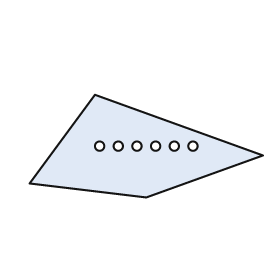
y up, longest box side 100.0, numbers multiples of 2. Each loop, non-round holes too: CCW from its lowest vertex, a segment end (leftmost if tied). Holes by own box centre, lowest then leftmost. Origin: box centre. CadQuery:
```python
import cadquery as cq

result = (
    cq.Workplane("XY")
    .moveTo(0.0, -22.0)
    .lineTo(50.0, -4.0)
    .lineTo(-22.0, 22.0)
    .lineTo(-50.0, -16.0)
    .close()
    .moveTo(-20.0, 0.0)
    .circle(2.0)
    .moveTo(-12.0, 0.0)
    .circle(2.0)
    .moveTo(-4.0, 0.0)
    .circle(2.0)
    .moveTo(4.0, 0.0)
    .circle(2.0)
    .moveTo(12.0, 0.0)
    .circle(2.0)
    .moveTo(20.0, 0.0)
    .circle(2.0)
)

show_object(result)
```